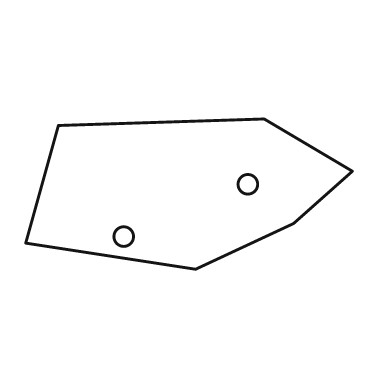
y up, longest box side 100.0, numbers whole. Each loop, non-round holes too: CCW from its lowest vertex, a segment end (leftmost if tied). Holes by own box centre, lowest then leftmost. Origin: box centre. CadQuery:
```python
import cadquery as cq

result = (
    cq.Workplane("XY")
    .moveTo(2.0, -23.0)
    .lineTo(32.0, -9.0)
    .lineTo(50.0, 7.0)
    .lineTo(23.0, 23.0)
    .lineTo(-40.0, 21.0)
    .lineTo(-50.0, -15.0)
    .close()
    .moveTo(-20.0, -13.0)
    .circle(3.0)
    .moveTo(18.0, 3.0)
    .circle(3.0)
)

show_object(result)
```